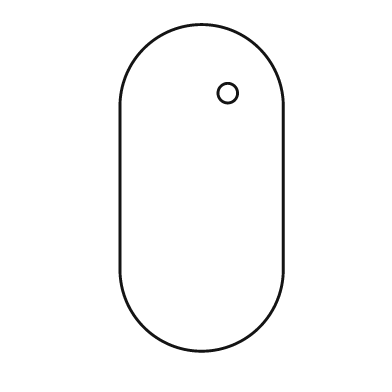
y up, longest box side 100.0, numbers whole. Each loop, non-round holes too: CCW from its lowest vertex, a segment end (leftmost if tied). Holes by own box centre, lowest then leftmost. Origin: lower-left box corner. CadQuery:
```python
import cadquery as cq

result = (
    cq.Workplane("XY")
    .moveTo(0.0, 25.0)
    .threePointArc((25.0, 0.0), (50.0, 25.0))
    .lineTo(50.0, 75.0)
    .threePointArc((25.0, 100.0), (0.0, 75.0))
    .close()
    .moveTo(33.0, 79.0)
    .circle(3.0)
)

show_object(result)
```